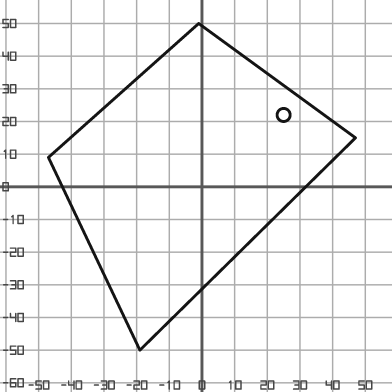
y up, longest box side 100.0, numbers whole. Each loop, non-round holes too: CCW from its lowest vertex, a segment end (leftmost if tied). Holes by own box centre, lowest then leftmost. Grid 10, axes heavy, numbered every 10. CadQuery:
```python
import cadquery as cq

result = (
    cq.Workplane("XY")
    .moveTo(-19.0, -50.0)
    .lineTo(47.0, 15.0)
    .lineTo(-1.0, 50.0)
    .lineTo(-47.0, 9.0)
    .close()
    .moveTo(25.0, 22.0)
    .circle(2.0)
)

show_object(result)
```